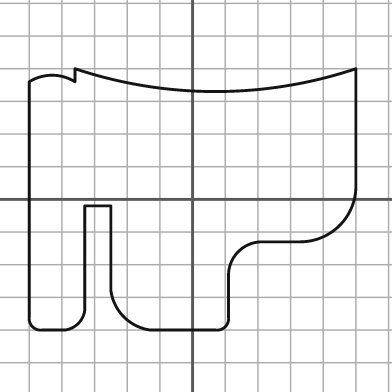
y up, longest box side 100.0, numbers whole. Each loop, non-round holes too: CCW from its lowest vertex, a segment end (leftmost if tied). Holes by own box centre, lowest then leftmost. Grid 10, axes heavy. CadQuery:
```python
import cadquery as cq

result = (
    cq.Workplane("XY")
    .moveTo(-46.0, -40.0)
    .lineTo(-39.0, -40.0)
    .threePointArc((-35.0, -38.0), (-33.0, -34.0))
    .lineTo(-33.0, -2.0)
    .lineTo(-25.0, -2.0)
    .lineTo(-25.0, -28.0)
    .threePointArc((-21.0, -36.0), (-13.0, -40.0))
    .lineTo(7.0, -40.0)
    .threePointArc((10.0, -39.0), (11.0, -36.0))
    .lineTo(11.0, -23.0)
    .threePointArc((14.0, -16.0), (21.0, -13.0))
    .lineTo(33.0, -13.0)
    .threePointArc((45.0, -8.0), (50.0, 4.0))
    .lineTo(50.0, 40.0)
    .threePointArc((7.0, 33.0), (-36.0, 40.0))
    .lineTo(-36.0, 36.0)
    .threePointArc((-43.0, 38.0), (-50.0, 36.0))
    .lineTo(-50.0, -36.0)
    .threePointArc((-49.0, -39.0), (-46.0, -40.0))
    .close()
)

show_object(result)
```